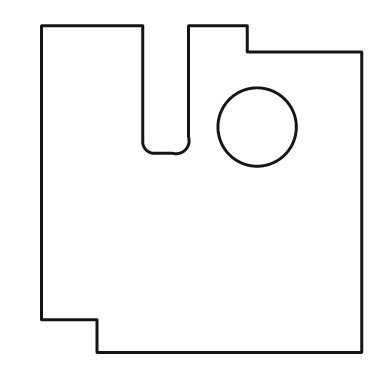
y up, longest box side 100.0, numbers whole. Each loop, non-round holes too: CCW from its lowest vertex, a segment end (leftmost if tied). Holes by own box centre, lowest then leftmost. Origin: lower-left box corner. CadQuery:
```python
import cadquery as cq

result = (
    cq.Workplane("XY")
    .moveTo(17.0, 0.0)
    .lineTo(98.0, 0.0)
    .lineTo(98.0, 92.0)
    .lineTo(63.0, 92.0)
    .lineTo(63.0, 100.0)
    .lineTo(45.0, 100.0)
    .lineTo(45.0, 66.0)
    .threePointArc((44.0, 62.0), (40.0, 61.0))
    .lineTo(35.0, 61.0)
    .threePointArc((32.0, 62.0), (31.0, 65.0))
    .lineTo(31.0, 100.0)
    .lineTo(0.0, 100.0)
    .lineTo(0.0, 10.0)
    .lineTo(17.0, 10.0)
    .close()
    .moveTo(66.0, 69.0)
    .circle(12.0)
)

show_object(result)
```